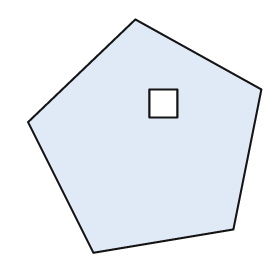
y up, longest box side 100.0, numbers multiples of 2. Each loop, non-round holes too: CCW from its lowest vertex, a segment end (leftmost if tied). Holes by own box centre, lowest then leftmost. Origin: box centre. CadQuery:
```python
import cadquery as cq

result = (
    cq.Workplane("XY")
    .moveTo(-22.0, -50.0)
    .lineTo(38.0, -40.0)
    .lineTo(50.0, 20.0)
    .lineTo(-4.0, 50.0)
    .lineTo(-50.0, 6.0)
    .close()
    .moveTo(2.0, 8.0)
    .lineTo(14.0, 8.0)
    .lineTo(14.0, 20.0)
    .lineTo(2.0, 20.0)
    .close()
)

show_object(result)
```